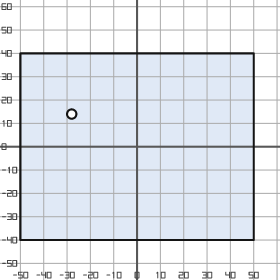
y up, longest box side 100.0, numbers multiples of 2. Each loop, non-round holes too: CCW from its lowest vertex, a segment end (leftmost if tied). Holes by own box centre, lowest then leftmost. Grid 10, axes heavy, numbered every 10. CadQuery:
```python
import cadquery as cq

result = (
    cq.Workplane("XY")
    .moveTo(-50.0, -40.0)
    .lineTo(50.0, -40.0)
    .lineTo(50.0, 40.0)
    .lineTo(-50.0, 40.0)
    .close()
    .moveTo(-28.0, 14.0)
    .circle(2.0)
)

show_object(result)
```